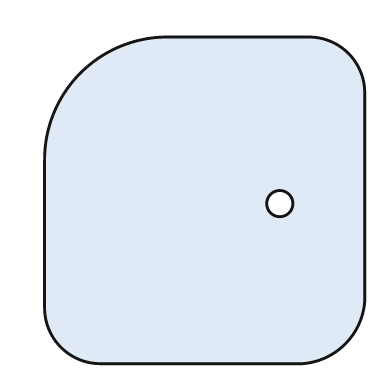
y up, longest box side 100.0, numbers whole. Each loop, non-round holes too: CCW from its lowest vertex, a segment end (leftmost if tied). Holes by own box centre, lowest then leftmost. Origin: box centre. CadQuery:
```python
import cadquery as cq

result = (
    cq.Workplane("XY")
    .moveTo(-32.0, -50.0)
    .lineTo(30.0, -50.0)
    .threePointArc((43.0, -44.0), (49.0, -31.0))
    .lineTo(49.0, 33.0)
    .threePointArc((44.0, 45.0), (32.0, 50.0))
    .lineTo(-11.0, 50.0)
    .threePointArc((-38.0, 39.0), (-49.0, 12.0))
    .lineTo(-49.0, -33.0)
    .threePointArc((-44.0, -45.0), (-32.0, -50.0))
    .close()
    .moveTo(23.0, -1.0)
    .circle(4.0)
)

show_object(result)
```